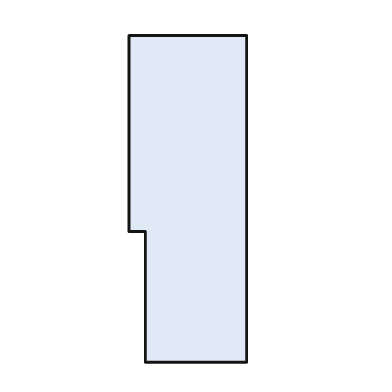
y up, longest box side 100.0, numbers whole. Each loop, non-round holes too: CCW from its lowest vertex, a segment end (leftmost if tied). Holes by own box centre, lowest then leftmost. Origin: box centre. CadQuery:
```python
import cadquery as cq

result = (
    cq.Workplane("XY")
    .moveTo(-13.0, -50.0)
    .lineTo(18.0, -50.0)
    .lineTo(18.0, 50.0)
    .lineTo(-18.0, 50.0)
    .lineTo(-18.0, -10.0)
    .lineTo(-13.0, -10.0)
    .close()
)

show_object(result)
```